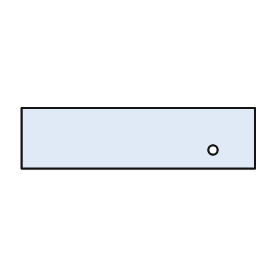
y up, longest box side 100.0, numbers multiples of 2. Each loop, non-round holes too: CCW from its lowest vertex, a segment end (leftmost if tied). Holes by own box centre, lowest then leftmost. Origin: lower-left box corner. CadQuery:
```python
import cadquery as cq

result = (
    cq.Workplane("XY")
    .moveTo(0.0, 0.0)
    .lineTo(100.0, 0.0)
    .lineTo(100.0, 26.0)
    .lineTo(0.0, 26.0)
    .close()
    .moveTo(82.0, 8.0)
    .circle(2.0)
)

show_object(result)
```